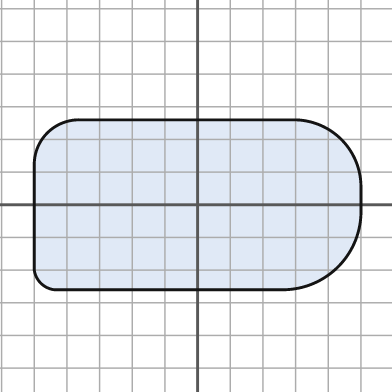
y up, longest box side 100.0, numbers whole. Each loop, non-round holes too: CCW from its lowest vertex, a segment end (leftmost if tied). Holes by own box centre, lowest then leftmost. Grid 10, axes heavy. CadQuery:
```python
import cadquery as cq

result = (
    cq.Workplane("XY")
    .moveTo(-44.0, -26.0)
    .lineTo(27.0, -26.0)
    .threePointArc((43.0, -19.0), (50.0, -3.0))
    .lineTo(50.0, 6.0)
    .threePointArc((44.0, 20.0), (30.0, 26.0))
    .lineTo(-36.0, 26.0)
    .threePointArc((-46.0, 22.0), (-50.0, 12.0))
    .lineTo(-50.0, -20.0)
    .threePointArc((-48.0, -24.0), (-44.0, -26.0))
    .close()
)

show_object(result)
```